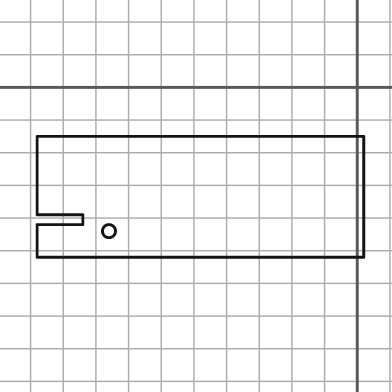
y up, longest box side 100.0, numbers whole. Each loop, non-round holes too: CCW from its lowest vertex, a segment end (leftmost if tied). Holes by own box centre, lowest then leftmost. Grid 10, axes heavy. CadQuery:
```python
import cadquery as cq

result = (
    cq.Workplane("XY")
    .moveTo(-98.0, -52.0)
    .lineTo(2.0, -52.0)
    .lineTo(2.0, -15.0)
    .lineTo(-98.0, -15.0)
    .lineTo(-98.0, -39.0)
    .lineTo(-84.0, -39.0)
    .lineTo(-84.0, -42.0)
    .lineTo(-98.0, -42.0)
    .close()
    .moveTo(-76.0, -44.0)
    .circle(2.0)
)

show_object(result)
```